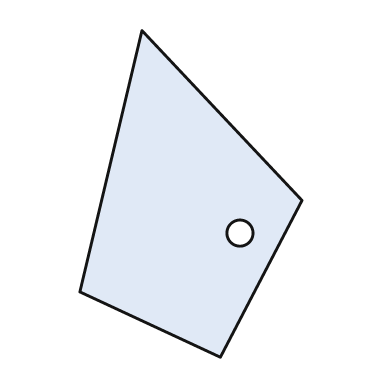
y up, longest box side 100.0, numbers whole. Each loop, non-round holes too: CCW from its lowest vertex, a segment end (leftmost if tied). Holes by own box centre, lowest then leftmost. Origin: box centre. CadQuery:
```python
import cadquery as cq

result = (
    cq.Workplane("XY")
    .moveTo(9.0, -50.0)
    .lineTo(34.0, -2.0)
    .lineTo(-15.0, 50.0)
    .lineTo(-34.0, -30.0)
    .close()
    .moveTo(15.0, -12.0)
    .circle(4.0)
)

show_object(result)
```